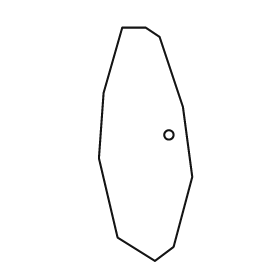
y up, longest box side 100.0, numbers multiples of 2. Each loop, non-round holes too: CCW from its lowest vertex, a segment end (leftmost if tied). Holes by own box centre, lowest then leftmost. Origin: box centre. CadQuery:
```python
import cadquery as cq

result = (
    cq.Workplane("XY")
    .moveTo(4.0, -50.0)
    .lineTo(12.0, -44.0)
    .lineTo(20.0, -14.0)
    .lineTo(16.0, 16.0)
    .lineTo(6.0, 46.0)
    .lineTo(0.0, 50.0)
    .lineTo(-10.0, 50.0)
    .lineTo(-18.0, 22.0)
    .lineTo(-20.0, -6.0)
    .lineTo(-12.0, -40.0)
    .close()
    .moveTo(10.0, 4.0)
    .circle(2.0)
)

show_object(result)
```